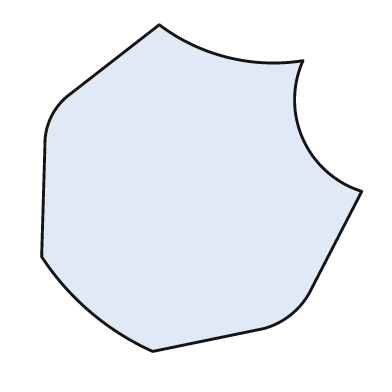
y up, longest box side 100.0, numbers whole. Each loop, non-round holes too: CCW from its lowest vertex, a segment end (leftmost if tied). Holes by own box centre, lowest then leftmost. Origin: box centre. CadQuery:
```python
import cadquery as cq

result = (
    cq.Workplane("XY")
    .moveTo(-15.0, -50.0)
    .lineTo(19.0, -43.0)
    .threePointArc((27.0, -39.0), (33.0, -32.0))
    .lineTo(49.0, -1.0)
    .threePointArc((31.0, 15.0), (31.0, 39.0))
    .threePointArc((8.0, 40.0), (-13.0, 50.0))
    .lineTo(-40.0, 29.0)
    .threePointArc((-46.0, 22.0), (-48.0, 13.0))
    .lineTo(-49.0, -21.0)
    .threePointArc((-34.0, -38.0), (-15.0, -50.0))
    .close()
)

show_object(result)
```